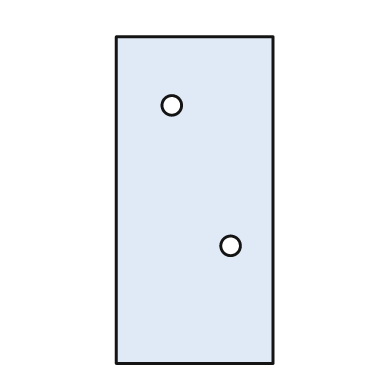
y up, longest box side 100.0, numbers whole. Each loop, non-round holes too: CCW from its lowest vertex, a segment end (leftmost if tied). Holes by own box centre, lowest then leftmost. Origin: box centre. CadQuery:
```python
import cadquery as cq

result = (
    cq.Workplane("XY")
    .moveTo(-24.0, -50.0)
    .lineTo(24.0, -50.0)
    .lineTo(24.0, 50.0)
    .lineTo(-24.0, 50.0)
    .close()
    .moveTo(11.0, -14.0)
    .circle(3.0)
    .moveTo(-7.0, 29.0)
    .circle(3.0)
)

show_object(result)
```